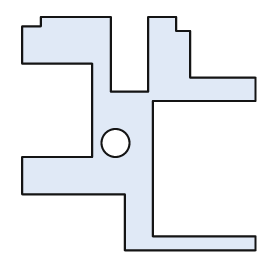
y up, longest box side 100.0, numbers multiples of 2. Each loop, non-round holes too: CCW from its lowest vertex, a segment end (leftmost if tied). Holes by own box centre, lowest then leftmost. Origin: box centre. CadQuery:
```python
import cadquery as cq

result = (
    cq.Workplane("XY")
    .moveTo(-6.0, -50.0)
    .lineTo(50.0, -50.0)
    .lineTo(50.0, -44.0)
    .lineTo(6.0, -44.0)
    .lineTo(6.0, 14.0)
    .lineTo(50.0, 14.0)
    .lineTo(50.0, 24.0)
    .lineTo(22.0, 24.0)
    .lineTo(22.0, 44.0)
    .lineTo(16.0, 44.0)
    .lineTo(16.0, 50.0)
    .lineTo(4.0, 50.0)
    .lineTo(4.0, 18.0)
    .lineTo(-12.0, 18.0)
    .lineTo(-12.0, 50.0)
    .lineTo(-42.0, 50.0)
    .lineTo(-42.0, 46.0)
    .lineTo(-50.0, 46.0)
    .lineTo(-50.0, 30.0)
    .lineTo(-20.0, 30.0)
    .lineTo(-20.0, -10.0)
    .lineTo(-50.0, -10.0)
    .lineTo(-50.0, -26.0)
    .lineTo(-6.0, -26.0)
    .close()
    .moveTo(-10.0, -4.0)
    .circle(6.0)
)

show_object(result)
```